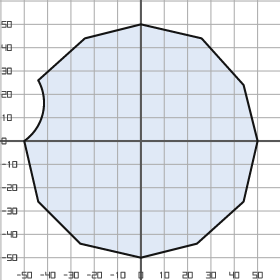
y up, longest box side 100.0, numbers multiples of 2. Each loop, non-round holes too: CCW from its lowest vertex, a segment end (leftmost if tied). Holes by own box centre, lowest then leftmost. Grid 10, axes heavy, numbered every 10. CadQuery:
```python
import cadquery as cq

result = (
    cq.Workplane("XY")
    .moveTo(0.0, -50.0)
    .lineTo(24.0, -44.0)
    .lineTo(44.0, -26.0)
    .lineTo(50.0, 0.0)
    .lineTo(44.0, 24.0)
    .lineTo(26.0, 44.0)
    .lineTo(0.0, 50.0)
    .lineTo(-24.0, 44.0)
    .lineTo(-44.0, 26.0)
    .threePointArc((-42.0, 12.0), (-50.0, 0.0))
    .lineTo(-44.0, -26.0)
    .lineTo(-26.0, -44.0)
    .close()
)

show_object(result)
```